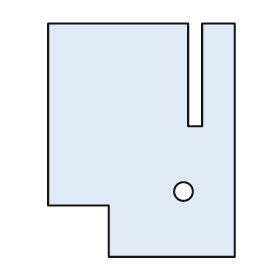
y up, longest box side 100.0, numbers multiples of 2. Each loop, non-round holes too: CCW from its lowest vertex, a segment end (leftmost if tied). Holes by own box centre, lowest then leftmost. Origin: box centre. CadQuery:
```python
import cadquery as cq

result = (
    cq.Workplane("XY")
    .moveTo(-14.0, -50.0)
    .lineTo(40.0, -50.0)
    .lineTo(40.0, 50.0)
    .lineTo(26.0, 50.0)
    .lineTo(26.0, 6.0)
    .lineTo(20.0, 6.0)
    .lineTo(20.0, 50.0)
    .lineTo(-40.0, 50.0)
    .lineTo(-40.0, -28.0)
    .lineTo(-14.0, -28.0)
    .close()
    .moveTo(18.0, -22.0)
    .circle(4.0)
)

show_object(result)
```